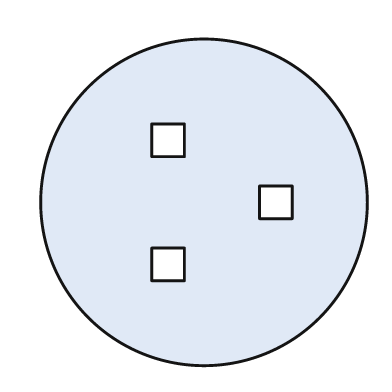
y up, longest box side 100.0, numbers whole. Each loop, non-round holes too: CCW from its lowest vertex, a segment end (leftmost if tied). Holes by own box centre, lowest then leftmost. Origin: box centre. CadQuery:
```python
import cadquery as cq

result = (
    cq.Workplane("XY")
    .moveTo(0.0, 0.0)
    .circle(50.0)
    .moveTo(-16.0, -24.0)
    .lineTo(-6.0, -24.0)
    .lineTo(-6.0, -14.0)
    .lineTo(-16.0, -14.0)
    .close()
    .moveTo(17.0, -5.0)
    .lineTo(27.0, -5.0)
    .lineTo(27.0, 5.0)
    .lineTo(17.0, 5.0)
    .close()
    .moveTo(-16.0, 14.0)
    .lineTo(-6.0, 14.0)
    .lineTo(-6.0, 24.0)
    .lineTo(-16.0, 24.0)
    .close()
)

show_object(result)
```